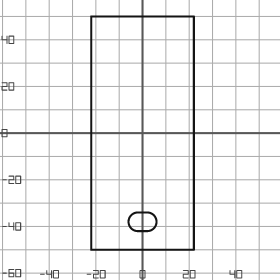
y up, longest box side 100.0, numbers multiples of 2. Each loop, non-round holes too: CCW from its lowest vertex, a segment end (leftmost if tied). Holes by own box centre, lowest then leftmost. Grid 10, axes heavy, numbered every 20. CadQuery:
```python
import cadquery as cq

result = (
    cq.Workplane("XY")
    .moveTo(-22.0, -50.0)
    .lineTo(22.0, -50.0)
    .lineTo(22.0, 50.0)
    .lineTo(-22.0, 50.0)
    .close()
    .moveTo(-2.0, -42.0)
    .lineTo(2.0, -42.0)
    .threePointArc((6.0, -38.0), (2.0, -34.0))
    .lineTo(-2.0, -34.0)
    .threePointArc((-6.0, -38.0), (-2.0, -42.0))
    .close()
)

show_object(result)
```